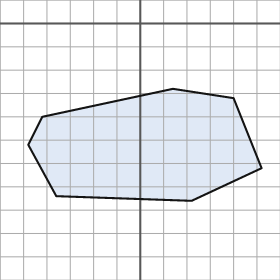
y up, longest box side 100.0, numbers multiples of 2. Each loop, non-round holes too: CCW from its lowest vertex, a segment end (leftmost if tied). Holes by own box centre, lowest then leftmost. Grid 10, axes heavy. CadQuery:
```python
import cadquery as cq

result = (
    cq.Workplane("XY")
    .moveTo(22.0, -76.0)
    .lineTo(52.0, -62.0)
    .lineTo(40.0, -32.0)
    .lineTo(14.0, -28.0)
    .lineTo(-42.0, -40.0)
    .lineTo(-48.0, -52.0)
    .lineTo(-36.0, -74.0)
    .close()
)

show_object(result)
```